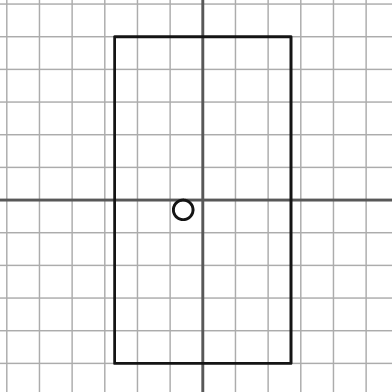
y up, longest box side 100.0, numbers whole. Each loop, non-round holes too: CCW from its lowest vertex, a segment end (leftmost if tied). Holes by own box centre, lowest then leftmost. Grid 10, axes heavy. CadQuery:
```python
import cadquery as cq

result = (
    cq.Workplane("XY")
    .moveTo(-27.0, -50.0)
    .lineTo(27.0, -50.0)
    .lineTo(27.0, 50.0)
    .lineTo(-27.0, 50.0)
    .close()
    .moveTo(-6.0, -3.0)
    .circle(3.0)
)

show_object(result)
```